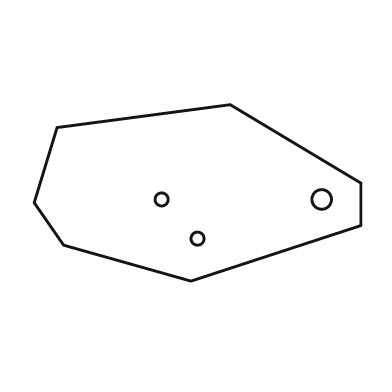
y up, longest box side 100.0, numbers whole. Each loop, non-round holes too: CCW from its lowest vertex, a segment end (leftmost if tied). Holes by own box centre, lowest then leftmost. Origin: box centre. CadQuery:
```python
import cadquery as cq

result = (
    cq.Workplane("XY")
    .moveTo(-2.0, -27.0)
    .lineTo(50.0, -10.0)
    .lineTo(50.0, 3.0)
    .lineTo(10.0, 27.0)
    .lineTo(-43.0, 20.0)
    .lineTo(-50.0, -3.0)
    .lineTo(-41.0, -16.0)
    .close()
    .moveTo(0.0, -14.0)
    .circle(2.0)
    .moveTo(-11.0, -2.0)
    .circle(2.0)
    .moveTo(38.0, -2.0)
    .circle(3.0)
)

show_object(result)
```